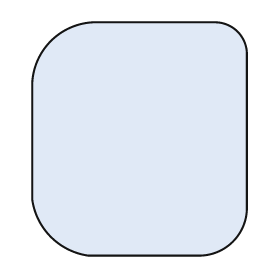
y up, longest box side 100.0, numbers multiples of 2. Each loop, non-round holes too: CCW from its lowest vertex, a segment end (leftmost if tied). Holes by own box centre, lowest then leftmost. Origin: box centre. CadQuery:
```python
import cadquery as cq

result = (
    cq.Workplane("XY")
    .moveTo(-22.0, -50.0)
    .lineTo(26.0, -50.0)
    .threePointArc((40.0, -44.0), (46.0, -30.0))
    .lineTo(46.0, 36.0)
    .threePointArc((42.0, 46.0), (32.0, 50.0))
    .lineTo(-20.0, 50.0)
    .threePointArc((-38.0, 42.0), (-46.0, 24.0))
    .lineTo(-46.0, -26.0)
    .threePointArc((-38.0, -42.0), (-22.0, -50.0))
    .close()
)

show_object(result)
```